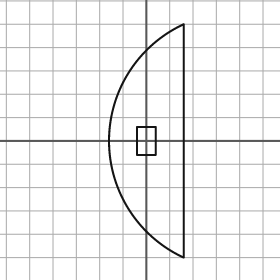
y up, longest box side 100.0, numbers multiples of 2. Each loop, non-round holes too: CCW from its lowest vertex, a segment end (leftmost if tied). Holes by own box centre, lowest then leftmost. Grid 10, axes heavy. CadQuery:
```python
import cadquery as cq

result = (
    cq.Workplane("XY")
    .moveTo(16.0, -50.0)
    .lineTo(16.0, 50.0)
    .threePointArc((-16.0, 0.0), (16.0, -50.0))
    .close()
    .moveTo(-4.0, -6.0)
    .lineTo(4.0, -6.0)
    .lineTo(4.0, 6.0)
    .lineTo(-4.0, 6.0)
    .close()
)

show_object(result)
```